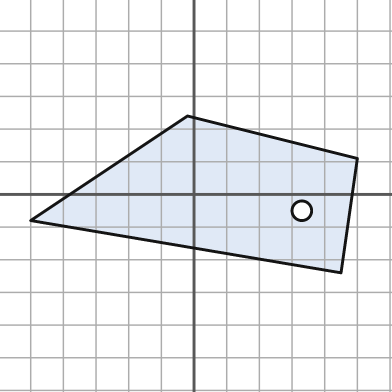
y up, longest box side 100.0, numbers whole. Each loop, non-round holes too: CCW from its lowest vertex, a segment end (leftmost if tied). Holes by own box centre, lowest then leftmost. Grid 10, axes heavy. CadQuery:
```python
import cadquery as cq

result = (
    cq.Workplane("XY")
    .moveTo(45.0, -24.0)
    .lineTo(50.0, 11.0)
    .lineTo(-2.0, 24.0)
    .lineTo(-50.0, -8.0)
    .close()
    .moveTo(33.0, -5.0)
    .circle(3.0)
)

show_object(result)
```